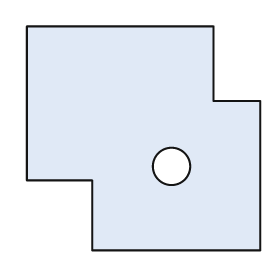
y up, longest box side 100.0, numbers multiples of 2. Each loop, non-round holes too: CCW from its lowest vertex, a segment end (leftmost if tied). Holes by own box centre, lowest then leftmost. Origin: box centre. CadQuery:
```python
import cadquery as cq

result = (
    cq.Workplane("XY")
    .moveTo(-22.0, -48.0)
    .lineTo(50.0, -48.0)
    .lineTo(50.0, 16.0)
    .lineTo(30.0, 16.0)
    .lineTo(30.0, 48.0)
    .lineTo(-50.0, 48.0)
    .lineTo(-50.0, -18.0)
    .lineTo(-22.0, -18.0)
    .close()
    .moveTo(12.0, -12.0)
    .circle(8.0)
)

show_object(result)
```